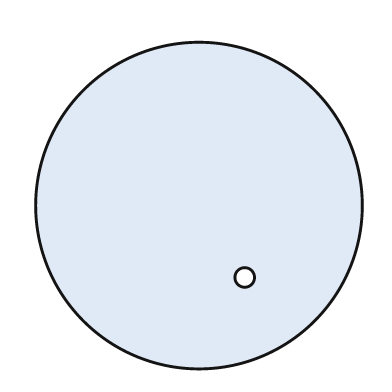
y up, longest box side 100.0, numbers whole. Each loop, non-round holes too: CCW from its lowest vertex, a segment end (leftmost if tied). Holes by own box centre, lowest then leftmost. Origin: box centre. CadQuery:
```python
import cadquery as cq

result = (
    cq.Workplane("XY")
    .moveTo(0.0, 0.0)
    .circle(50.0)
    .moveTo(14.0, -22.0)
    .circle(3.0)
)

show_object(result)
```